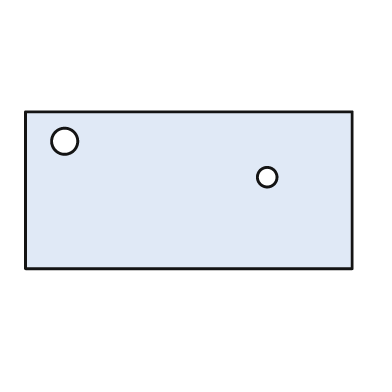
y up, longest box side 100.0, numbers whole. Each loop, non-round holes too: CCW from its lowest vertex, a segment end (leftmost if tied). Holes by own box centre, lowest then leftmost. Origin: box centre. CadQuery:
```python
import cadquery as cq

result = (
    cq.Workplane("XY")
    .moveTo(-50.0, -24.0)
    .lineTo(50.0, -24.0)
    .lineTo(50.0, 24.0)
    .lineTo(-50.0, 24.0)
    .close()
    .moveTo(24.0, 4.0)
    .circle(3.0)
    .moveTo(-38.0, 15.0)
    .circle(4.0)
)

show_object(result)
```